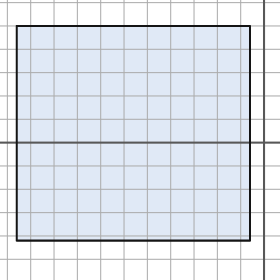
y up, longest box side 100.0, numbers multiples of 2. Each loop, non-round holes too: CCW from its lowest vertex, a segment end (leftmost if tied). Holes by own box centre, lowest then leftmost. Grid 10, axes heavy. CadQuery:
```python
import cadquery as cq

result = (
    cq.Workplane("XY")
    .moveTo(-106.0, -42.0)
    .lineTo(-6.0, -42.0)
    .lineTo(-6.0, 50.0)
    .lineTo(-106.0, 50.0)
    .close()
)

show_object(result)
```